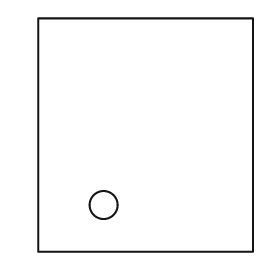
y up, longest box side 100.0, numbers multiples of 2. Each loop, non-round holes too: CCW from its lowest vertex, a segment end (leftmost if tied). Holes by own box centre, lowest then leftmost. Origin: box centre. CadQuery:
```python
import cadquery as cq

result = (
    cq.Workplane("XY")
    .moveTo(-46.0, -50.0)
    .lineTo(46.0, -50.0)
    .lineTo(46.0, 50.0)
    .lineTo(-46.0, 50.0)
    .close()
    .moveTo(-18.0, -30.0)
    .circle(6.0)
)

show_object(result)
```